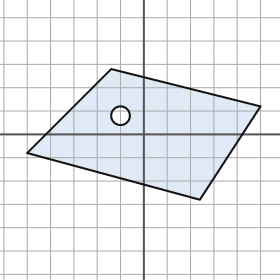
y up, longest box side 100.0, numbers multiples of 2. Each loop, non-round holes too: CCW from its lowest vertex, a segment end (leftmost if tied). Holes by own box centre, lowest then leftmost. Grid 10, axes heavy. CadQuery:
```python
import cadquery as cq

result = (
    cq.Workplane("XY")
    .moveTo(24.0, -28.0)
    .lineTo(50.0, 12.0)
    .lineTo(-14.0, 28.0)
    .lineTo(-50.0, -8.0)
    .close()
    .moveTo(-10.0, 8.0)
    .circle(4.0)
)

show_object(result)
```